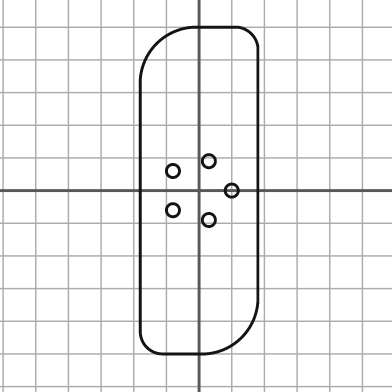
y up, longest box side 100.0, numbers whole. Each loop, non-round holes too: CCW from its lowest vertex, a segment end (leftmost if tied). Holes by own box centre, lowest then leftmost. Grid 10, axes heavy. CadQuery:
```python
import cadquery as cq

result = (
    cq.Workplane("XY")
    .moveTo(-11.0, -50.0)
    .lineTo(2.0, -50.0)
    .threePointArc((13.0, -45.0), (18.0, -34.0))
    .lineTo(18.0, 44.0)
    .threePointArc((16.0, 48.0), (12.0, 50.0))
    .lineTo(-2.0, 50.0)
    .threePointArc((-13.0, 45.0), (-18.0, 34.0))
    .lineTo(-18.0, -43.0)
    .threePointArc((-16.0, -48.0), (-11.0, -50.0))
    .close()
    .moveTo(3.0, -9.0)
    .circle(2.0)
    .moveTo(-8.0, -6.0)
    .circle(2.0)
    .moveTo(10.0, 0.0)
    .circle(2.0)
    .moveTo(-8.0, 6.0)
    .circle(2.0)
    .moveTo(3.0, 9.0)
    .circle(2.0)
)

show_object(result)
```